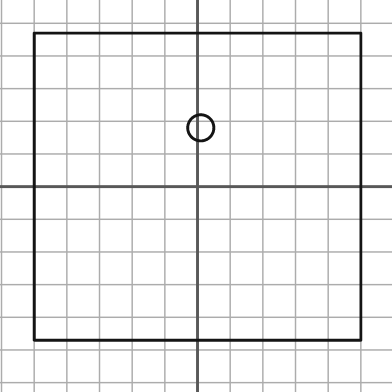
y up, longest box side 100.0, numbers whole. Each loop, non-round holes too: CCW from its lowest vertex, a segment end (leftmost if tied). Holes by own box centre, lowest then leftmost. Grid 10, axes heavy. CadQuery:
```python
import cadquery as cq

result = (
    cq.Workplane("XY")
    .moveTo(-50.0, -47.0)
    .lineTo(50.0, -47.0)
    .lineTo(50.0, 47.0)
    .lineTo(-50.0, 47.0)
    .close()
    .moveTo(1.0, 18.0)
    .circle(4.0)
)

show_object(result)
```